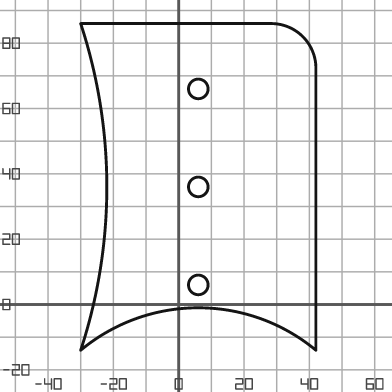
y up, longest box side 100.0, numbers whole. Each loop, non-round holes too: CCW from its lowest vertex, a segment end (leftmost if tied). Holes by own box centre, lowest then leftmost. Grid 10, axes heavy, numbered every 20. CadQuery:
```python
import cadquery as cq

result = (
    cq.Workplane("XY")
    .moveTo(-30.0, -14.0)
    .threePointArc((6.0, -1.0), (42.0, -14.0))
    .lineTo(42.0, 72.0)
    .threePointArc((38.0, 82.0), (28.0, 86.0))
    .lineTo(-30.0, 86.0)
    .threePointArc((-22.0, 36.0), (-30.0, -14.0))
    .close()
    .moveTo(6.0, 6.0)
    .circle(3.0)
    .moveTo(6.0, 36.0)
    .circle(3.0)
    .moveTo(6.0, 66.0)
    .circle(3.0)
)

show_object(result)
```